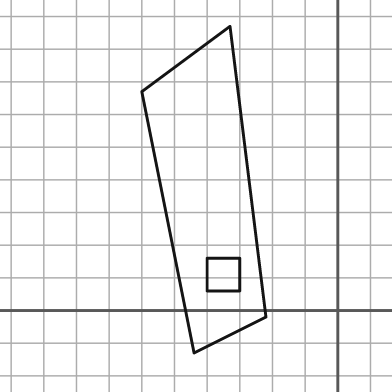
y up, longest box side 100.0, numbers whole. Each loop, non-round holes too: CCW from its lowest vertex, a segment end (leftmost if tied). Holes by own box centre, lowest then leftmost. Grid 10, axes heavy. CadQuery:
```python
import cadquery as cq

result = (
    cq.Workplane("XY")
    .moveTo(-44.0, -13.0)
    .lineTo(-22.0, -2.0)
    .lineTo(-33.0, 87.0)
    .lineTo(-60.0, 67.0)
    .close()
    .moveTo(-40.0, 6.0)
    .lineTo(-30.0, 6.0)
    .lineTo(-30.0, 16.0)
    .lineTo(-40.0, 16.0)
    .close()
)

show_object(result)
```